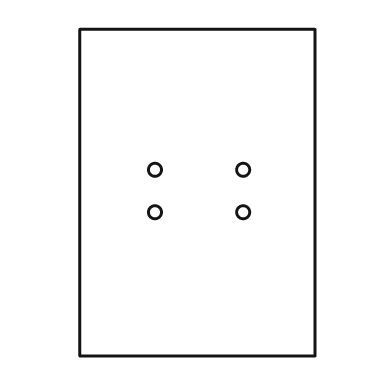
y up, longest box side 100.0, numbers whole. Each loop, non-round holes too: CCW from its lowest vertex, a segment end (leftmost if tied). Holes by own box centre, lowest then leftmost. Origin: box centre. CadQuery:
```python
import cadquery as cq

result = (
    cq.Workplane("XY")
    .moveTo(-36.0, -50.0)
    .lineTo(36.0, -50.0)
    .lineTo(36.0, 50.0)
    .lineTo(-36.0, 50.0)
    .close()
    .moveTo(-13.0, -6.0)
    .circle(2.0)
    .moveTo(14.0, -6.0)
    .circle(2.0)
    .moveTo(-13.0, 7.0)
    .circle(2.0)
    .moveTo(14.0, 7.0)
    .circle(2.0)
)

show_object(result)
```